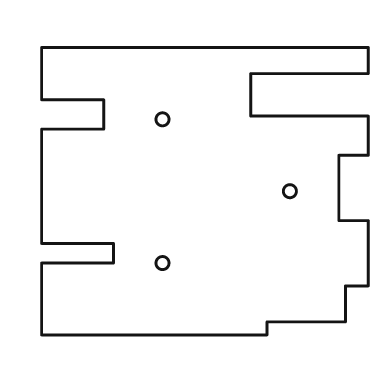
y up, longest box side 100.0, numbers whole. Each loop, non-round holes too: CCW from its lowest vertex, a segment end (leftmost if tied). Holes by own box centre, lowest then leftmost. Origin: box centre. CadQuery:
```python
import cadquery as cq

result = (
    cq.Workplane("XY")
    .moveTo(-50.0, -44.0)
    .lineTo(19.0, -44.0)
    .lineTo(19.0, -40.0)
    .lineTo(43.0, -40.0)
    .lineTo(43.0, -29.0)
    .lineTo(50.0, -29.0)
    .lineTo(50.0, -9.0)
    .lineTo(41.0, -9.0)
    .lineTo(41.0, 11.0)
    .lineTo(50.0, 11.0)
    .lineTo(50.0, 23.0)
    .lineTo(14.0, 23.0)
    .lineTo(14.0, 36.0)
    .lineTo(50.0, 36.0)
    .lineTo(50.0, 44.0)
    .lineTo(-50.0, 44.0)
    .lineTo(-50.0, 28.0)
    .lineTo(-31.0, 28.0)
    .lineTo(-31.0, 19.0)
    .lineTo(-50.0, 19.0)
    .lineTo(-50.0, -16.0)
    .lineTo(-28.0, -16.0)
    .lineTo(-28.0, -22.0)
    .lineTo(-50.0, -22.0)
    .close()
    .moveTo(-13.0, -22.0)
    .circle(2.0)
    .moveTo(26.0, 0.0)
    .circle(2.0)
    .moveTo(-13.0, 22.0)
    .circle(2.0)
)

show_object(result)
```